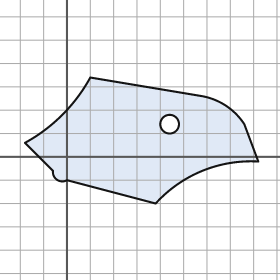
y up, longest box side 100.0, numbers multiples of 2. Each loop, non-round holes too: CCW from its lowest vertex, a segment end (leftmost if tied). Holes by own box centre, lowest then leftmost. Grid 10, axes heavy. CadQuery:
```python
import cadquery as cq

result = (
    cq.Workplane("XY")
    .moveTo(38.0, -20.0)
    .threePointArc((58.0, -6.0), (82.0, -2.0))
    .lineTo(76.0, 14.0)
    .threePointArc((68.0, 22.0), (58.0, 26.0))
    .lineTo(10.0, 34.0)
    .threePointArc((-2.0, 18.0), (-18.0, 6.0))
    .lineTo(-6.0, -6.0)
    .threePointArc((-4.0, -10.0), (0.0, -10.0))
    .close()
    .moveTo(44.0, 14.0)
    .circle(4.0)
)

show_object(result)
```